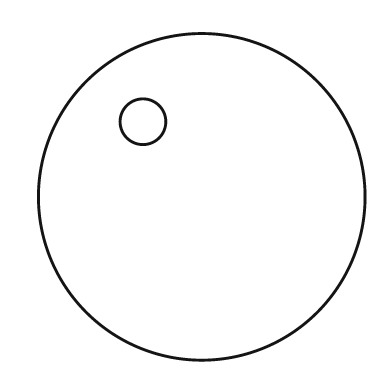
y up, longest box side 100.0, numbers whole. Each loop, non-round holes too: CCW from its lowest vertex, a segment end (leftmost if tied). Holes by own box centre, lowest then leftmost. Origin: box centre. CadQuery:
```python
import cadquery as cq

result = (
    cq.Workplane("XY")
    .moveTo(0.0, 0.0)
    .circle(50.0)
    .moveTo(-18.0, 23.0)
    .circle(7.0)
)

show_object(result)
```